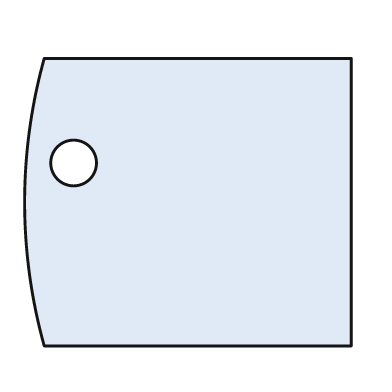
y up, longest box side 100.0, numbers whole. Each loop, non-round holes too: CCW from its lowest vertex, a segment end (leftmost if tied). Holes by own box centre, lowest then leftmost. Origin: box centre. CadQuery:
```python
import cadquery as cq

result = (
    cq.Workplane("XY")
    .moveTo(-44.0, -44.0)
    .lineTo(50.0, -44.0)
    .lineTo(50.0, 44.0)
    .lineTo(-44.0, 44.0)
    .threePointArc((-50.0, 0.0), (-44.0, -44.0))
    .close()
    .moveTo(-35.0, 12.0)
    .circle(7.0)
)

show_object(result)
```